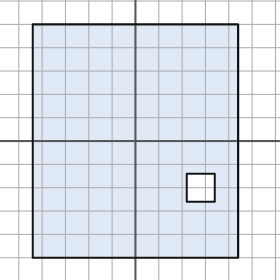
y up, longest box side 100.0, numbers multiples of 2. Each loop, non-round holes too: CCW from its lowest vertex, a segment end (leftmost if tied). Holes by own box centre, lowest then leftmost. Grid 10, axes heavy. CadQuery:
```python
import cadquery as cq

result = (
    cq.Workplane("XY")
    .moveTo(-44.0, -50.0)
    .lineTo(44.0, -50.0)
    .lineTo(44.0, 50.0)
    .lineTo(-44.0, 50.0)
    .close()
    .moveTo(22.0, -26.0)
    .lineTo(34.0, -26.0)
    .lineTo(34.0, -14.0)
    .lineTo(22.0, -14.0)
    .close()
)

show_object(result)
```